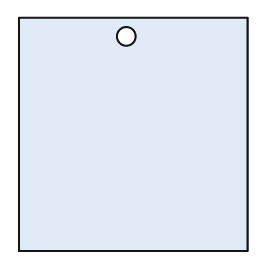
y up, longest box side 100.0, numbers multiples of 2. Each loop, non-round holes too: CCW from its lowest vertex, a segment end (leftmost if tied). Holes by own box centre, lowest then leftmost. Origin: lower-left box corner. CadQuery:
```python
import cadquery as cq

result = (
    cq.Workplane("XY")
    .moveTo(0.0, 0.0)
    .lineTo(98.0, 0.0)
    .lineTo(98.0, 100.0)
    .lineTo(0.0, 100.0)
    .close()
    .moveTo(46.0, 92.0)
    .circle(4.0)
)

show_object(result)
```